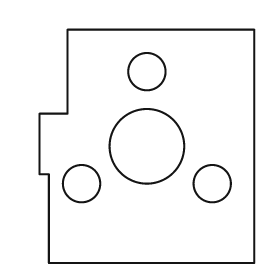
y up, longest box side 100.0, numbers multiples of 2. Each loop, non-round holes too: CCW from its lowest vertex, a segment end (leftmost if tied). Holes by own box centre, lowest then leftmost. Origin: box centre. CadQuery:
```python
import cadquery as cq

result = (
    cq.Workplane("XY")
    .moveTo(-42.0, -50.0)
    .lineTo(46.0, -50.0)
    .lineTo(46.0, 50.0)
    .lineTo(-34.0, 50.0)
    .lineTo(-34.0, 14.0)
    .lineTo(-46.0, 14.0)
    .lineTo(-46.0, -12.0)
    .lineTo(-42.0, -12.0)
    .close()
    .moveTo(-28.0, -16.0)
    .circle(8.0)
    .moveTo(28.0, -16.0)
    .circle(8.0)
    .moveTo(0.0, 0.0)
    .circle(16.0)
    .moveTo(0.0, 32.0)
    .circle(8.0)
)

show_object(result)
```